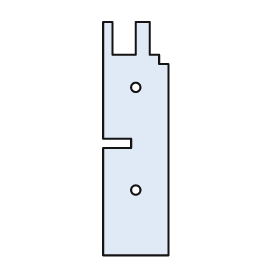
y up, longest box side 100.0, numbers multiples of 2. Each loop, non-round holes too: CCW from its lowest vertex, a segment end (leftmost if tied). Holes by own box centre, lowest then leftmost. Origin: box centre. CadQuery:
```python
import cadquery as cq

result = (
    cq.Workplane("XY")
    .moveTo(-14.0, -50.0)
    .lineTo(14.0, -50.0)
    .lineTo(14.0, 32.0)
    .lineTo(10.0, 32.0)
    .lineTo(10.0, 36.0)
    .lineTo(6.0, 36.0)
    .lineTo(6.0, 50.0)
    .lineTo(0.0, 50.0)
    .lineTo(0.0, 36.0)
    .lineTo(-10.0, 36.0)
    .lineTo(-10.0, 50.0)
    .lineTo(-14.0, 50.0)
    .lineTo(-14.0, 0.0)
    .lineTo(-2.0, 0.0)
    .lineTo(-2.0, -4.0)
    .lineTo(-14.0, -4.0)
    .close()
    .moveTo(0.0, -22.0)
    .circle(2.0)
    .moveTo(0.0, 22.0)
    .circle(2.0)
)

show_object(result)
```